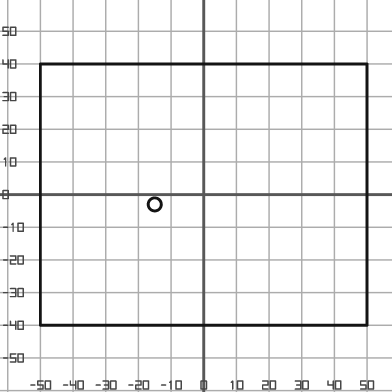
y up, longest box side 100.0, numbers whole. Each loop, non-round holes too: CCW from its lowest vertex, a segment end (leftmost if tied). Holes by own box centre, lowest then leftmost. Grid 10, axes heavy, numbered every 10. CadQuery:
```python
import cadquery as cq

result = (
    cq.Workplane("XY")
    .moveTo(-50.0, -40.0)
    .lineTo(50.0, -40.0)
    .lineTo(50.0, 40.0)
    .lineTo(-50.0, 40.0)
    .close()
    .moveTo(-15.0, -3.0)
    .circle(2.0)
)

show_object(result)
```